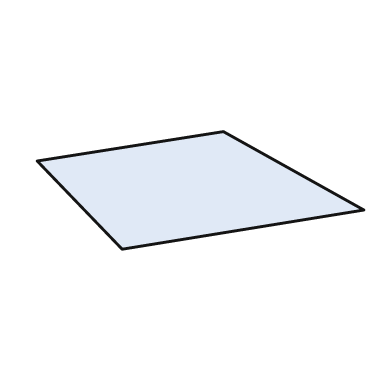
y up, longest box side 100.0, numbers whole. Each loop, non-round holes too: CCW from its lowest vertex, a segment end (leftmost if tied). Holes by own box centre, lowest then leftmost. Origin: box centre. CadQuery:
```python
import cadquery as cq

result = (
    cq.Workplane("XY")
    .moveTo(-24.0, -18.0)
    .lineTo(50.0, -6.0)
    .lineTo(7.0, 18.0)
    .lineTo(-50.0, 9.0)
    .close()
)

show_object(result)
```